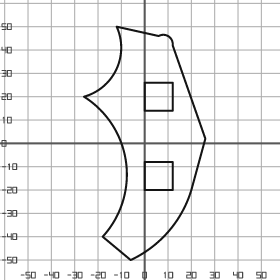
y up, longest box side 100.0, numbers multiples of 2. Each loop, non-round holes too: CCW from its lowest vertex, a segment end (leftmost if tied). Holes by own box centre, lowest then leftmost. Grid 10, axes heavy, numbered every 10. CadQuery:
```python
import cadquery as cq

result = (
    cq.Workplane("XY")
    .moveTo(-6.0, -50.0)
    .threePointArc((10.0, -38.0), (20.0, -20.0))
    .lineTo(26.0, 2.0)
    .lineTo(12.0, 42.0)
    .threePointArc((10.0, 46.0), (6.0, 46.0))
    .lineTo(-12.0, 50.0)
    .threePointArc((-12.0, 32.0), (-26.0, 20.0))
    .threePointArc((-8.0, -8.0), (-18.0, -40.0))
    .close()
    .moveTo(0.0, -20.0)
    .lineTo(12.0, -20.0)
    .lineTo(12.0, -8.0)
    .lineTo(0.0, -8.0)
    .close()
    .moveTo(0.0, 14.0)
    .lineTo(12.0, 14.0)
    .lineTo(12.0, 26.0)
    .lineTo(0.0, 26.0)
    .close()
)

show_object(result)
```